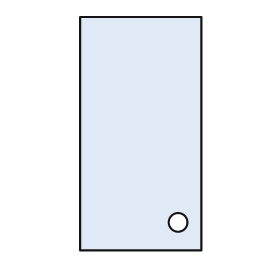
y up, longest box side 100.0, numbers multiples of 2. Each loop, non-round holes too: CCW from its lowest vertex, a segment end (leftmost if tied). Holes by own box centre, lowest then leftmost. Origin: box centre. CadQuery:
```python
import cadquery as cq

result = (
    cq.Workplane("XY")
    .moveTo(-26.0, -50.0)
    .lineTo(26.0, -50.0)
    .lineTo(26.0, 50.0)
    .lineTo(-26.0, 50.0)
    .close()
    .moveTo(16.0, -38.0)
    .circle(4.0)
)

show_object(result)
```